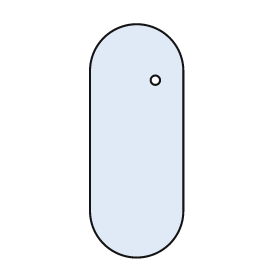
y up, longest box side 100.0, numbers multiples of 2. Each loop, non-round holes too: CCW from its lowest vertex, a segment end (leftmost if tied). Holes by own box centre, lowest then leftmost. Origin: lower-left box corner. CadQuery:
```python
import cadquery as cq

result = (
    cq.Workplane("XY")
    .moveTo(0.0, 20.0)
    .threePointArc((20.0, 0.0), (40.0, 20.0))
    .lineTo(40.0, 80.0)
    .threePointArc((20.0, 100.0), (0.0, 80.0))
    .close()
    .moveTo(28.0, 76.0)
    .circle(2.0)
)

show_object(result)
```